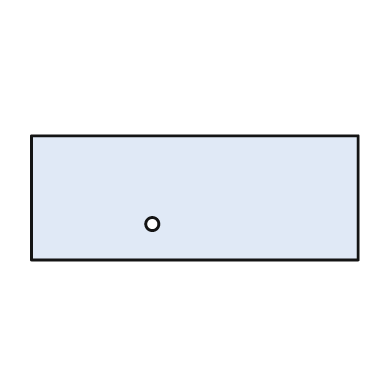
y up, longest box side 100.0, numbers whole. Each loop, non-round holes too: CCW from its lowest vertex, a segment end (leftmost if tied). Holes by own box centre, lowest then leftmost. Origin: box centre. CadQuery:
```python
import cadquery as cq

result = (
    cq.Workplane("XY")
    .moveTo(-50.0, -19.0)
    .lineTo(50.0, -19.0)
    .lineTo(50.0, 19.0)
    .lineTo(-50.0, 19.0)
    .close()
    .moveTo(-13.0, -8.0)
    .circle(2.0)
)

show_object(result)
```